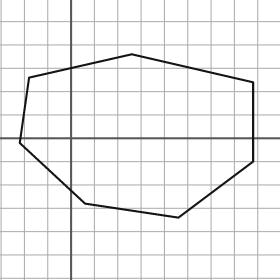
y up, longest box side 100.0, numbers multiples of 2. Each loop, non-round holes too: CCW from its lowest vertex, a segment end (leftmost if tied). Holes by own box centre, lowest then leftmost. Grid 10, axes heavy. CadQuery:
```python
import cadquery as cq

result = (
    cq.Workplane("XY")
    .moveTo(46.0, -34.0)
    .lineTo(78.0, -10.0)
    .lineTo(78.0, 24.0)
    .lineTo(26.0, 36.0)
    .lineTo(-18.0, 26.0)
    .lineTo(-22.0, -2.0)
    .lineTo(6.0, -28.0)
    .close()
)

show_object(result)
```